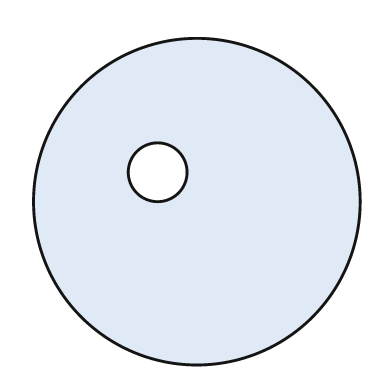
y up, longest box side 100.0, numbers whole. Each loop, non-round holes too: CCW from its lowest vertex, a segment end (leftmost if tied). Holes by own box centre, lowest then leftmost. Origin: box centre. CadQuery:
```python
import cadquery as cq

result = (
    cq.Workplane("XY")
    .moveTo(0.0, 0.0)
    .circle(50.0)
    .moveTo(-12.0, 9.0)
    .circle(9.0)
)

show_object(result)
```